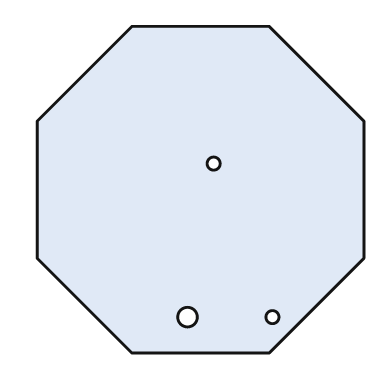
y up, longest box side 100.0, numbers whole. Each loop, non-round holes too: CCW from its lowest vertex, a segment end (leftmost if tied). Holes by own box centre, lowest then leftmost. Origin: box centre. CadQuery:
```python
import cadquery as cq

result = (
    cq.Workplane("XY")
    .moveTo(-21.0, -50.0)
    .lineTo(21.0, -50.0)
    .lineTo(50.0, -21.0)
    .lineTo(50.0, 21.0)
    .lineTo(21.0, 50.0)
    .lineTo(-21.0, 50.0)
    .lineTo(-50.0, 21.0)
    .lineTo(-50.0, -21.0)
    .close()
    .moveTo(-4.0, -39.0)
    .circle(3.0)
    .moveTo(22.0, -39.0)
    .circle(2.0)
    .moveTo(4.0, 8.0)
    .circle(2.0)
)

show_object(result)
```